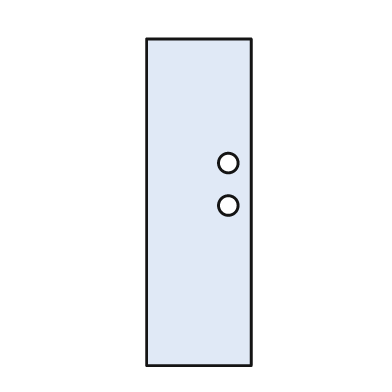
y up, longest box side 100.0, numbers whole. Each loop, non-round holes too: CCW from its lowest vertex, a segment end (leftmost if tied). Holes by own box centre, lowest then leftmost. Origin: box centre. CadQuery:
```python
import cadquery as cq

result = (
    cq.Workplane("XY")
    .moveTo(-16.0, -50.0)
    .lineTo(16.0, -50.0)
    .lineTo(16.0, 50.0)
    .lineTo(-16.0, 50.0)
    .close()
    .moveTo(9.0, -1.0)
    .circle(3.0)
    .moveTo(9.0, 12.0)
    .circle(3.0)
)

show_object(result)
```